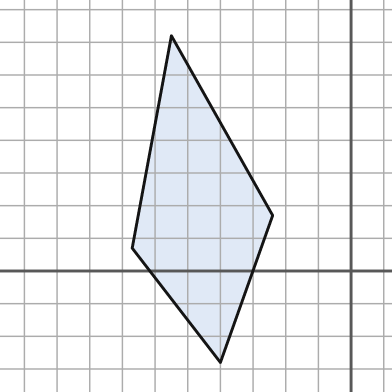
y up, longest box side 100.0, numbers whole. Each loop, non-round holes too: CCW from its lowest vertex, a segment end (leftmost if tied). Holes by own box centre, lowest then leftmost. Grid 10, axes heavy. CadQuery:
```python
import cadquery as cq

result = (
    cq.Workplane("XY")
    .moveTo(-40.0, -28.0)
    .lineTo(-24.0, 17.0)
    .lineTo(-55.0, 72.0)
    .lineTo(-67.0, 7.0)
    .close()
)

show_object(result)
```